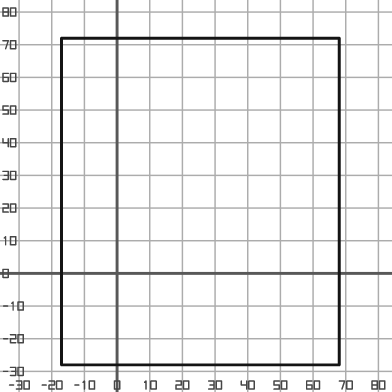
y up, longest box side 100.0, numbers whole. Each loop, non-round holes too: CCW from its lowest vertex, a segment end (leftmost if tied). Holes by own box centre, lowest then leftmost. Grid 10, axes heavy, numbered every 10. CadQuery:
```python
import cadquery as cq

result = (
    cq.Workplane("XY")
    .moveTo(-17.0, -28.0)
    .lineTo(68.0, -28.0)
    .lineTo(68.0, 72.0)
    .lineTo(-17.0, 72.0)
    .close()
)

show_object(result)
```